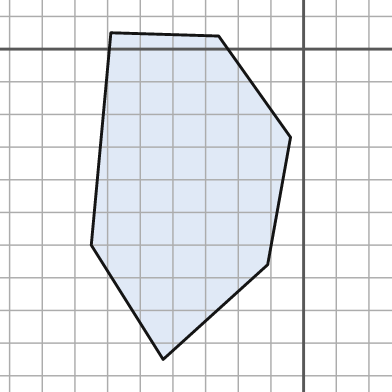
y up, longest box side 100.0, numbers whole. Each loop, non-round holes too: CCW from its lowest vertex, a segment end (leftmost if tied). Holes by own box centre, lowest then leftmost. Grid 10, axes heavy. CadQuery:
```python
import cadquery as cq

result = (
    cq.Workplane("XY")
    .moveTo(-43.0, -95.0)
    .lineTo(-11.0, -66.0)
    .lineTo(-4.0, -27.0)
    .lineTo(-26.0, 4.0)
    .lineTo(-59.0, 5.0)
    .lineTo(-65.0, -60.0)
    .close()
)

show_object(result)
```